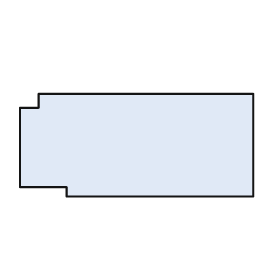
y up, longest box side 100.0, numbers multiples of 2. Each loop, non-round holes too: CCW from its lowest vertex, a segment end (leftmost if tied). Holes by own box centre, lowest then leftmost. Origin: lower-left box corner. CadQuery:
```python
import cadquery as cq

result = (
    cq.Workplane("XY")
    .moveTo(20.0, 0.0)
    .lineTo(100.0, 0.0)
    .lineTo(100.0, 44.0)
    .lineTo(8.0, 44.0)
    .lineTo(8.0, 38.0)
    .lineTo(0.0, 38.0)
    .lineTo(0.0, 4.0)
    .lineTo(20.0, 4.0)
    .close()
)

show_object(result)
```